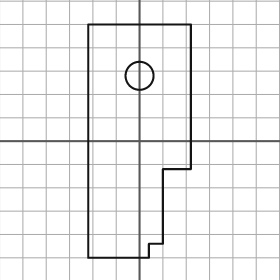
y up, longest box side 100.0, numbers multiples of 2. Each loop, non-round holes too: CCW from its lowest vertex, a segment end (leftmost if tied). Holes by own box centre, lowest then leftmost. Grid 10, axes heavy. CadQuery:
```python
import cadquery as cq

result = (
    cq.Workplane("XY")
    .moveTo(-22.0, -50.0)
    .lineTo(4.0, -50.0)
    .lineTo(4.0, -44.0)
    .lineTo(10.0, -44.0)
    .lineTo(10.0, -12.0)
    .lineTo(22.0, -12.0)
    .lineTo(22.0, 50.0)
    .lineTo(-22.0, 50.0)
    .close()
    .moveTo(0.0, 28.0)
    .circle(6.0)
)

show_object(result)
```